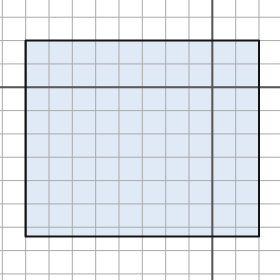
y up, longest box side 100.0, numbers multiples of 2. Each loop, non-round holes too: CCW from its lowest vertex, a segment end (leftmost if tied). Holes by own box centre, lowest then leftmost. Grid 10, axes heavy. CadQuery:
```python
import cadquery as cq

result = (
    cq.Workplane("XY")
    .moveTo(-80.0, -64.0)
    .lineTo(20.0, -64.0)
    .lineTo(20.0, 20.0)
    .lineTo(-80.0, 20.0)
    .close()
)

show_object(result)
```